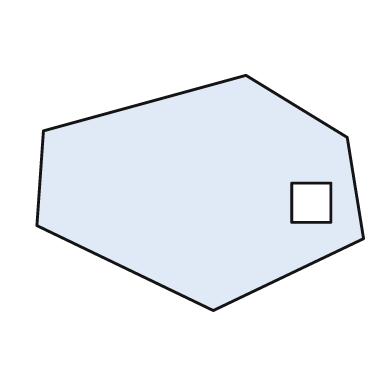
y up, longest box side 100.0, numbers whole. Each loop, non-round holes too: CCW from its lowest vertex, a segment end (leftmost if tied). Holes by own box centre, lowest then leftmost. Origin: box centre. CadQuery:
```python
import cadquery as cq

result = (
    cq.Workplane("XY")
    .moveTo(4.0, -36.0)
    .lineTo(50.0, -14.0)
    .lineTo(45.0, 17.0)
    .lineTo(14.0, 36.0)
    .lineTo(-48.0, 19.0)
    .lineTo(-50.0, -10.0)
    .close()
    .moveTo(28.0, -9.0)
    .lineTo(40.0, -9.0)
    .lineTo(40.0, 3.0)
    .lineTo(28.0, 3.0)
    .close()
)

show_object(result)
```